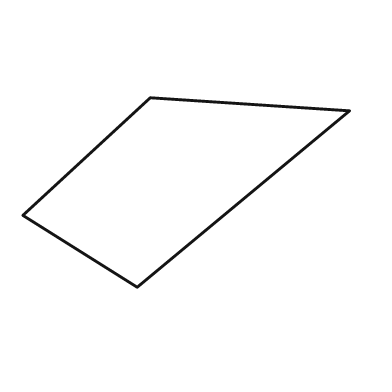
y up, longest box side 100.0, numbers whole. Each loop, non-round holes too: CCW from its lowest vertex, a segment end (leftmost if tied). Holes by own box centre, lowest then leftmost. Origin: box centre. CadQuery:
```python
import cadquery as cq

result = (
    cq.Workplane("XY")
    .moveTo(-15.0, -29.0)
    .lineTo(50.0, 25.0)
    .lineTo(-11.0, 29.0)
    .lineTo(-50.0, -7.0)
    .close()
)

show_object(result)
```